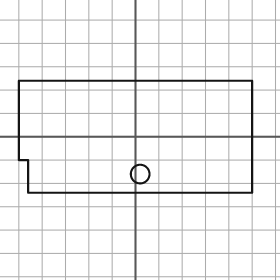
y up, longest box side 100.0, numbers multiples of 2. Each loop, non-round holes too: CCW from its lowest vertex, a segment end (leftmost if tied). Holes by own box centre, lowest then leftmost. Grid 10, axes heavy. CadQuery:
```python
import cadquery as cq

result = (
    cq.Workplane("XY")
    .moveTo(-46.0, -24.0)
    .lineTo(50.0, -24.0)
    .lineTo(50.0, 24.0)
    .lineTo(-50.0, 24.0)
    .lineTo(-50.0, -10.0)
    .lineTo(-46.0, -10.0)
    .close()
    .moveTo(2.0, -16.0)
    .circle(4.0)
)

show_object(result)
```